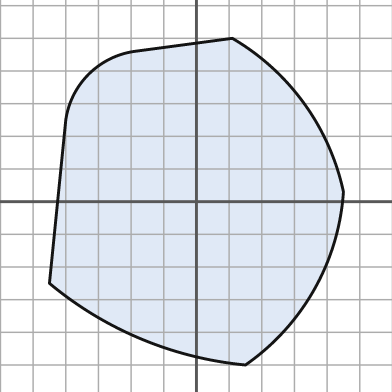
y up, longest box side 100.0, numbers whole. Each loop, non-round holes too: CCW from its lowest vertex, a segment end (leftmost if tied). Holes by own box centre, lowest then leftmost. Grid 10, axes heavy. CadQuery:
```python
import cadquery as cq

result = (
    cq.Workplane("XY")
    .moveTo(15.0, -50.0)
    .threePointArc((36.0, -27.0), (45.0, 3.0))
    .threePointArc((33.0, 30.0), (11.0, 50.0))
    .lineTo(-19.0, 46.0)
    .threePointArc((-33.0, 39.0), (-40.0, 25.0))
    .lineTo(-45.0, -25.0)
    .threePointArc((-17.0, -42.0), (15.0, -50.0))
    .close()
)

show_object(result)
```